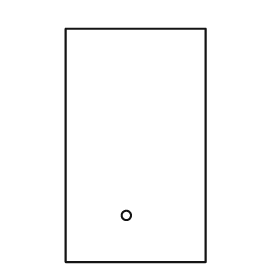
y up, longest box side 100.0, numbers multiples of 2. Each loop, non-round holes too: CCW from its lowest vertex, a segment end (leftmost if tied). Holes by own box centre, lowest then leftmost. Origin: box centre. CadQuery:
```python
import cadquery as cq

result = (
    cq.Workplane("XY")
    .moveTo(-30.0, -50.0)
    .lineTo(30.0, -50.0)
    .lineTo(30.0, 50.0)
    .lineTo(-30.0, 50.0)
    .close()
    .moveTo(-4.0, -30.0)
    .circle(2.0)
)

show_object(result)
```